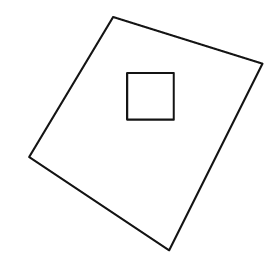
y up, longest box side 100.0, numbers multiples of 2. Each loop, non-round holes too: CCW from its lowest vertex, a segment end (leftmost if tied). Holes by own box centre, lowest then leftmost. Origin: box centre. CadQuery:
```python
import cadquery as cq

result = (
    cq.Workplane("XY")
    .moveTo(10.0, -50.0)
    .lineTo(50.0, 30.0)
    .lineTo(-14.0, 50.0)
    .lineTo(-50.0, -10.0)
    .close()
    .moveTo(-8.0, 6.0)
    .lineTo(12.0, 6.0)
    .lineTo(12.0, 26.0)
    .lineTo(-8.0, 26.0)
    .close()
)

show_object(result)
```